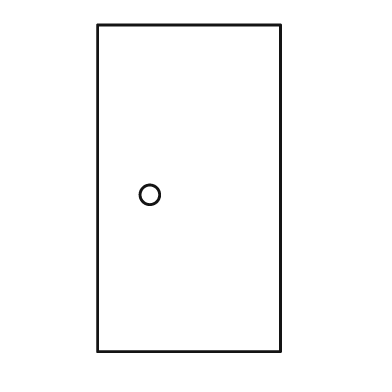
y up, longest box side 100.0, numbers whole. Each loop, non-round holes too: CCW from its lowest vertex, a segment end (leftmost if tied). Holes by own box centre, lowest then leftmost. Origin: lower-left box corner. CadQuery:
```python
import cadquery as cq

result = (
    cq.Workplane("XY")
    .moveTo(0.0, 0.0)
    .lineTo(56.0, 0.0)
    .lineTo(56.0, 100.0)
    .lineTo(0.0, 100.0)
    .close()
    .moveTo(16.0, 48.0)
    .circle(3.0)
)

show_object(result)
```